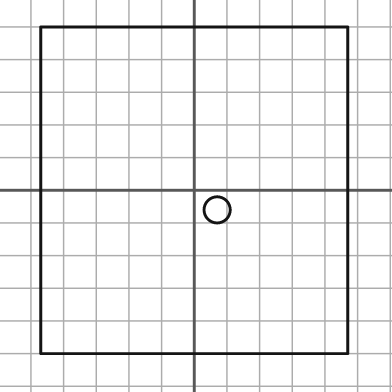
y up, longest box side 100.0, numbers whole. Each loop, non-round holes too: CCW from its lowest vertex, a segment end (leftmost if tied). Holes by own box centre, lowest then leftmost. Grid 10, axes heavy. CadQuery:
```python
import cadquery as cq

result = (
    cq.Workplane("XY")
    .moveTo(-47.0, -50.0)
    .lineTo(47.0, -50.0)
    .lineTo(47.0, 50.0)
    .lineTo(-47.0, 50.0)
    .close()
    .moveTo(7.0, -6.0)
    .circle(4.0)
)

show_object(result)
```